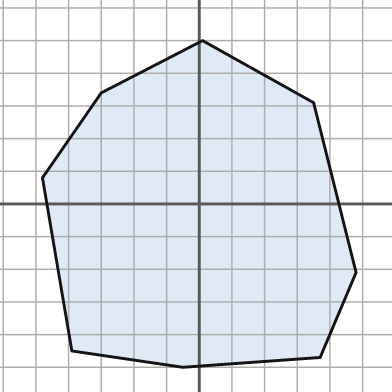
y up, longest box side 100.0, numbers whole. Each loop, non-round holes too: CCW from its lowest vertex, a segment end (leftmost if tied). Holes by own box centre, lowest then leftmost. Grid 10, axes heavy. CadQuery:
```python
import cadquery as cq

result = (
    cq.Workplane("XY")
    .moveTo(-5.0, -50.0)
    .lineTo(37.0, -47.0)
    .lineTo(48.0, -21.0)
    .lineTo(35.0, 31.0)
    .lineTo(1.0, 50.0)
    .lineTo(-30.0, 34.0)
    .lineTo(-48.0, 8.0)
    .lineTo(-39.0, -45.0)
    .close()
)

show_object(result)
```